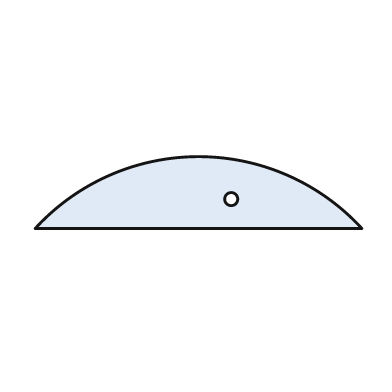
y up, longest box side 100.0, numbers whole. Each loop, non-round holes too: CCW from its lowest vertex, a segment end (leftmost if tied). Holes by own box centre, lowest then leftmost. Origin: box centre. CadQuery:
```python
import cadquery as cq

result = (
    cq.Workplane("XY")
    .moveTo(-50.0, -11.0)
    .lineTo(50.0, -11.0)
    .threePointArc((0.0, 11.0), (-50.0, -11.0))
    .close()
    .moveTo(10.0, -2.0)
    .circle(2.0)
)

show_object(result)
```